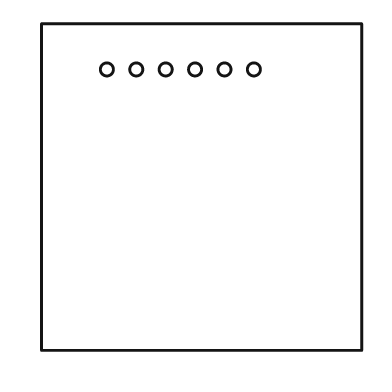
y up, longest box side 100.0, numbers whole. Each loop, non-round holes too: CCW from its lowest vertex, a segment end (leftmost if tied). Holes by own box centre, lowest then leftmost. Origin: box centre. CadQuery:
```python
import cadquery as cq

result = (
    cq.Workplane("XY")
    .moveTo(-49.0, -50.0)
    .lineTo(49.0, -50.0)
    .lineTo(49.0, 50.0)
    .lineTo(-49.0, 50.0)
    .close()
    .moveTo(-29.0, 36.0)
    .circle(2.0)
    .moveTo(-20.0, 36.0)
    .circle(2.0)
    .moveTo(-11.0, 36.0)
    .circle(2.0)
    .moveTo(-2.0, 36.0)
    .circle(2.0)
    .moveTo(7.0, 36.0)
    .circle(2.0)
    .moveTo(16.0, 36.0)
    .circle(2.0)
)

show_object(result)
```